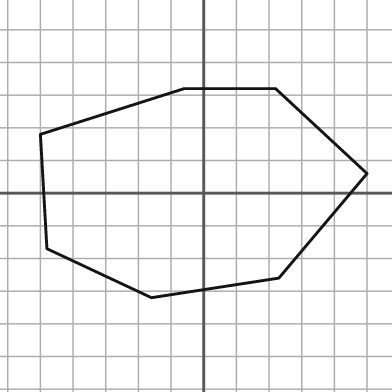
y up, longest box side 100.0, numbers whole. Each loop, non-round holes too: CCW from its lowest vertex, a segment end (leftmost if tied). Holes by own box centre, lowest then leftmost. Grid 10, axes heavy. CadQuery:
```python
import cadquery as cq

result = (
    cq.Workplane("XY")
    .moveTo(-16.0, -32.0)
    .lineTo(23.0, -26.0)
    .lineTo(50.0, 6.0)
    .lineTo(22.0, 32.0)
    .lineTo(-6.0, 32.0)
    .lineTo(-50.0, 18.0)
    .lineTo(-48.0, -17.0)
    .close()
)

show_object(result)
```